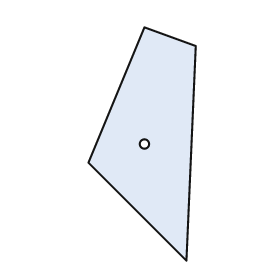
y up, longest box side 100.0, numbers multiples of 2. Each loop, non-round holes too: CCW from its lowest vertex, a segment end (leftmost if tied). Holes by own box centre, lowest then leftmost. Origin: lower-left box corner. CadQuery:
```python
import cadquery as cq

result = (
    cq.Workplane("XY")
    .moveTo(42.0, 0.0)
    .lineTo(46.0, 92.0)
    .lineTo(24.0, 100.0)
    .lineTo(0.0, 42.0)
    .close()
    .moveTo(24.0, 50.0)
    .circle(2.0)
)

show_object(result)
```